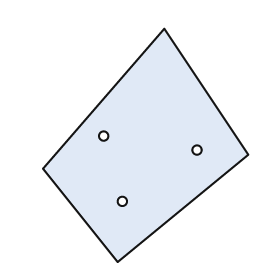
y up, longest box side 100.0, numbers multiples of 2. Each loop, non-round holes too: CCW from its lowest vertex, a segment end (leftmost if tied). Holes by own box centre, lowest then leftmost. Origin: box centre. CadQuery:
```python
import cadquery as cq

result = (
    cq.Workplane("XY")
    .moveTo(-12.0, -50.0)
    .lineTo(44.0, -4.0)
    .lineTo(8.0, 50.0)
    .lineTo(-44.0, -10.0)
    .close()
    .moveTo(-10.0, -24.0)
    .circle(2.0)
    .moveTo(22.0, -2.0)
    .circle(2.0)
    .moveTo(-18.0, 4.0)
    .circle(2.0)
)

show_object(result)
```